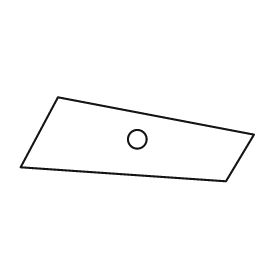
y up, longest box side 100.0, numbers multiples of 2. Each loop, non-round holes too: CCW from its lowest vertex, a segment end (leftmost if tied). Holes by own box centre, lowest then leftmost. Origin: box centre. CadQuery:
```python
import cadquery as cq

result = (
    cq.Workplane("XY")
    .moveTo(38.0, -18.0)
    .lineTo(50.0, 2.0)
    .lineTo(-34.0, 18.0)
    .lineTo(-50.0, -12.0)
    .close()
    .moveTo(0.0, 0.0)
    .circle(4.0)
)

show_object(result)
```